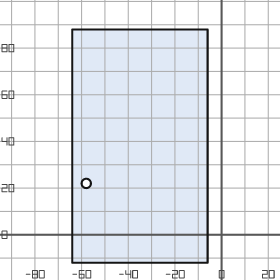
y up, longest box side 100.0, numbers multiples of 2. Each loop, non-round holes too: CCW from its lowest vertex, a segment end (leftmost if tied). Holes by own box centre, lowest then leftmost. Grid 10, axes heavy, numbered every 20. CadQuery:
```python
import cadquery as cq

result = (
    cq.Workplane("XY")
    .moveTo(-64.0, -12.0)
    .lineTo(-6.0, -12.0)
    .lineTo(-6.0, 88.0)
    .lineTo(-64.0, 88.0)
    .close()
    .moveTo(-58.0, 22.0)
    .circle(2.0)
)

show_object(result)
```